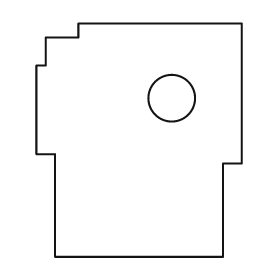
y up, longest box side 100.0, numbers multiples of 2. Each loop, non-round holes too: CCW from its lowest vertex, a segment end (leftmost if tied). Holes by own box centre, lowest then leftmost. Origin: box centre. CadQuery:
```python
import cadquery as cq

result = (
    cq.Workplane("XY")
    .moveTo(-36.0, -50.0)
    .lineTo(36.0, -50.0)
    .lineTo(36.0, -10.0)
    .lineTo(44.0, -10.0)
    .lineTo(44.0, 50.0)
    .lineTo(-26.0, 50.0)
    .lineTo(-26.0, 44.0)
    .lineTo(-40.0, 44.0)
    .lineTo(-40.0, 32.0)
    .lineTo(-44.0, 32.0)
    .lineTo(-44.0, -6.0)
    .lineTo(-36.0, -6.0)
    .close()
    .moveTo(14.0, 18.0)
    .circle(10.0)
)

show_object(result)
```